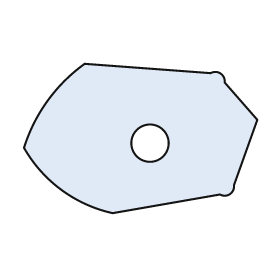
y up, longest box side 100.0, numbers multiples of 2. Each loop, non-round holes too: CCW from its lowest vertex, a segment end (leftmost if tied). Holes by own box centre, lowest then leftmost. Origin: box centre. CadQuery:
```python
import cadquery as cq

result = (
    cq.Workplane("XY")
    .moveTo(-12.0, -32.0)
    .lineTo(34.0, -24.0)
    .threePointArc((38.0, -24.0), (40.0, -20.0))
    .lineTo(50.0, 8.0)
    .lineTo(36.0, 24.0)
    .threePointArc((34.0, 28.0), (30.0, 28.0))
    .lineTo(-24.0, 32.0)
    .threePointArc((-40.0, 16.0), (-50.0, -4.0))
    .threePointArc((-34.0, -22.0), (-12.0, -32.0))
    .close()
    .moveTo(4.0, -2.0)
    .circle(8.0)
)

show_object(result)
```